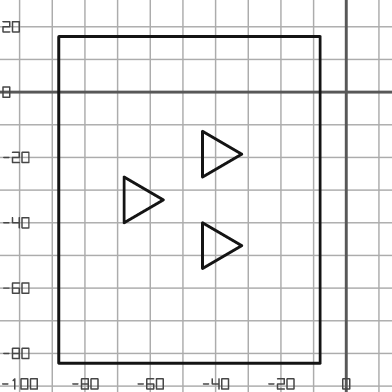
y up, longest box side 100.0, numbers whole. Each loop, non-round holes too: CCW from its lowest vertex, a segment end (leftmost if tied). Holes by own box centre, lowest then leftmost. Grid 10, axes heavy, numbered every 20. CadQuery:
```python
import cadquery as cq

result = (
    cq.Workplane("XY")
    .moveTo(-88.0, -83.0)
    .lineTo(-8.0, -83.0)
    .lineTo(-8.0, 17.0)
    .lineTo(-88.0, 17.0)
    .close()
    .moveTo(-44.0, -54.0)
    .lineTo(-32.0, -47.0)
    .lineTo(-44.0, -40.0)
    .close()
    .moveTo(-68.0, -40.0)
    .lineTo(-56.0, -33.0)
    .lineTo(-68.0, -26.0)
    .close()
    .moveTo(-44.0, -26.0)
    .lineTo(-32.0, -19.0)
    .lineTo(-44.0, -12.0)
    .close()
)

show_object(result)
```